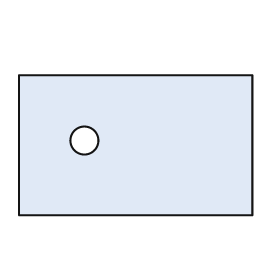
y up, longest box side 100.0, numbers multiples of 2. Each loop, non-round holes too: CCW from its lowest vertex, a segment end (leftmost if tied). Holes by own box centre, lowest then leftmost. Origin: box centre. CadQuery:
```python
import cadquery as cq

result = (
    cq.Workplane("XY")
    .moveTo(-50.0, -30.0)
    .lineTo(50.0, -30.0)
    .lineTo(50.0, 30.0)
    .lineTo(-50.0, 30.0)
    .close()
    .moveTo(-22.0, 2.0)
    .circle(6.0)
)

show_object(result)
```